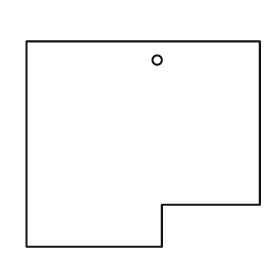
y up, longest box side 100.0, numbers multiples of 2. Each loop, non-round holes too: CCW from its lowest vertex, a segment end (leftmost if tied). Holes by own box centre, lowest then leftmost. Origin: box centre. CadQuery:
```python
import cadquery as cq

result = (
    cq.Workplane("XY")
    .moveTo(-50.0, -44.0)
    .lineTo(8.0, -44.0)
    .lineTo(8.0, -26.0)
    .lineTo(50.0, -26.0)
    .lineTo(50.0, 44.0)
    .lineTo(-50.0, 44.0)
    .close()
    .moveTo(6.0, 36.0)
    .circle(2.0)
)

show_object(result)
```